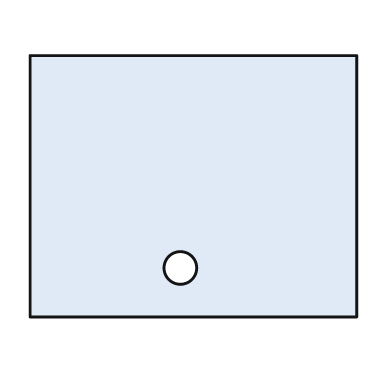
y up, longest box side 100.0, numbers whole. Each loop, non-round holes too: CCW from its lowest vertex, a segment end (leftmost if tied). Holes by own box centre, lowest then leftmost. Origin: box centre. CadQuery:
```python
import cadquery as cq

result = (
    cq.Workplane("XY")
    .moveTo(-50.0, -40.0)
    .lineTo(50.0, -40.0)
    .lineTo(50.0, 40.0)
    .lineTo(-50.0, 40.0)
    .close()
    .moveTo(-4.0, -25.0)
    .circle(5.0)
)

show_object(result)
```